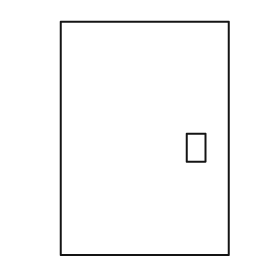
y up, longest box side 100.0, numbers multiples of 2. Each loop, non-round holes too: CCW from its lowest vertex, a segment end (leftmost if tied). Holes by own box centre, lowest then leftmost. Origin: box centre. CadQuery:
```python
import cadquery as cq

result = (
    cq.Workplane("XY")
    .moveTo(-36.0, -50.0)
    .lineTo(36.0, -50.0)
    .lineTo(36.0, 50.0)
    .lineTo(-36.0, 50.0)
    .close()
    .moveTo(18.0, -10.0)
    .lineTo(26.0, -10.0)
    .lineTo(26.0, 2.0)
    .lineTo(18.0, 2.0)
    .close()
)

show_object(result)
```